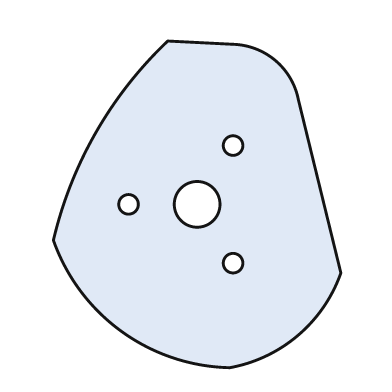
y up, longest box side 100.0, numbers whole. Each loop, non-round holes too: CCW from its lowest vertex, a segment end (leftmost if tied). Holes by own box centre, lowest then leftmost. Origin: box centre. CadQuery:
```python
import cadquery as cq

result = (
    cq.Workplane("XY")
    .moveTo(10.0, -50.0)
    .threePointArc((31.0, -40.0), (44.0, -21.0))
    .lineTo(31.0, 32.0)
    .threePointArc((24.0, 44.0), (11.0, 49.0))
    .lineTo(-9.0, 50.0)
    .threePointArc((-31.0, 22.0), (-44.0, -11.0))
    .threePointArc((-23.0, -39.0), (10.0, -50.0))
    .close()
    .moveTo(11.0, -18.0)
    .circle(3.0)
    .moveTo(-21.0, 0.0)
    .circle(3.0)
    .moveTo(0.0, 0.0)
    .circle(7.0)
    .moveTo(11.0, 18.0)
    .circle(3.0)
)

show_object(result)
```